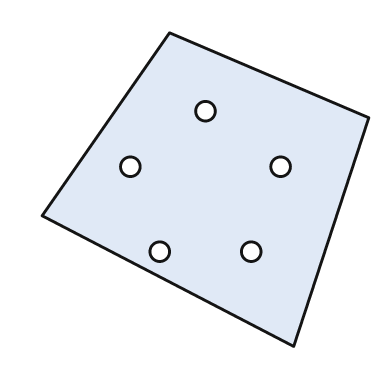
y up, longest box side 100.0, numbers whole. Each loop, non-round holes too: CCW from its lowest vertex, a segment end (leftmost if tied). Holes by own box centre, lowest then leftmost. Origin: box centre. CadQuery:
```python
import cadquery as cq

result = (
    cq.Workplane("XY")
    .moveTo(27.0, -48.0)
    .lineTo(50.0, 22.0)
    .lineTo(-11.0, 48.0)
    .lineTo(-50.0, -8.0)
    .close()
    .moveTo(-14.0, -19.0)
    .circle(3.0)
    .moveTo(14.0, -19.0)
    .circle(3.0)
    .moveTo(-23.0, 7.0)
    .circle(3.0)
    .moveTo(23.0, 7.0)
    .circle(3.0)
    .moveTo(0.0, 24.0)
    .circle(3.0)
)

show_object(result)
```